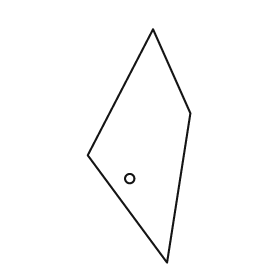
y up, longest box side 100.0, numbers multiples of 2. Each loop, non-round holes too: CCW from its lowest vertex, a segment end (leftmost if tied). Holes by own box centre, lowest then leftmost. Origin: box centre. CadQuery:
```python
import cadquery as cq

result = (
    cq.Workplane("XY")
    .moveTo(12.0, -50.0)
    .lineTo(22.0, 14.0)
    .lineTo(6.0, 50.0)
    .lineTo(-22.0, -4.0)
    .close()
    .moveTo(-4.0, -14.0)
    .circle(2.0)
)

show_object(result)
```